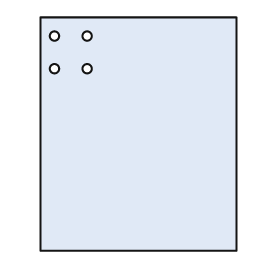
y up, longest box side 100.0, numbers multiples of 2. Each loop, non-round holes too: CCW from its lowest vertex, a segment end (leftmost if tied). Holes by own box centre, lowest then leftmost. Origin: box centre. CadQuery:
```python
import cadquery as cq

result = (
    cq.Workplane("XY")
    .moveTo(-42.0, -50.0)
    .lineTo(42.0, -50.0)
    .lineTo(42.0, 50.0)
    .lineTo(-42.0, 50.0)
    .close()
    .moveTo(-36.0, 28.0)
    .circle(2.0)
    .moveTo(-22.0, 28.0)
    .circle(2.0)
    .moveTo(-36.0, 42.0)
    .circle(2.0)
    .moveTo(-22.0, 42.0)
    .circle(2.0)
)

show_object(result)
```